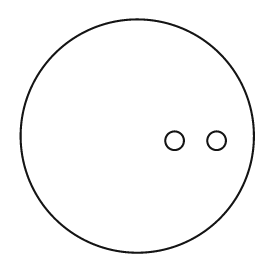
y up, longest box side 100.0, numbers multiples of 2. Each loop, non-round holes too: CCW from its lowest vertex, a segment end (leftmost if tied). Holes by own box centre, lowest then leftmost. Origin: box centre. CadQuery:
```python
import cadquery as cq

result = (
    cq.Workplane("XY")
    .moveTo(0.0, 0.0)
    .circle(50.0)
    .moveTo(16.0, -2.0)
    .circle(4.0)
    .moveTo(34.0, -2.0)
    .circle(4.0)
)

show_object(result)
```